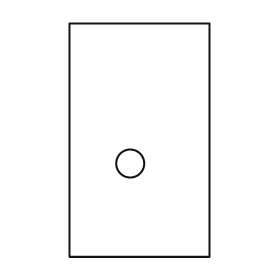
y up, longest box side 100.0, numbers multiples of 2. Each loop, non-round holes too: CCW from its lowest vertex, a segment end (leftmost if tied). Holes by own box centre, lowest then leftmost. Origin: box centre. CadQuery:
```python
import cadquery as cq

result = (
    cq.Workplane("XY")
    .moveTo(-30.0, -50.0)
    .lineTo(30.0, -50.0)
    .lineTo(30.0, 50.0)
    .lineTo(-30.0, 50.0)
    .close()
    .moveTo(-4.0, -10.0)
    .circle(6.0)
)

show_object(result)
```